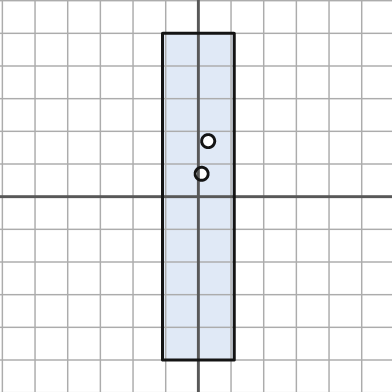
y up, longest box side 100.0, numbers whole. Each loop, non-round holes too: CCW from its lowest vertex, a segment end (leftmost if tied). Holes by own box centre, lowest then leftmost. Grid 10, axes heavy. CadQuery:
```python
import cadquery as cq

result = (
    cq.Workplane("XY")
    .moveTo(-11.0, -50.0)
    .lineTo(11.0, -50.0)
    .lineTo(11.0, 50.0)
    .lineTo(-11.0, 50.0)
    .close()
    .moveTo(1.0, 7.0)
    .circle(2.0)
    .moveTo(3.0, 17.0)
    .circle(2.0)
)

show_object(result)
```